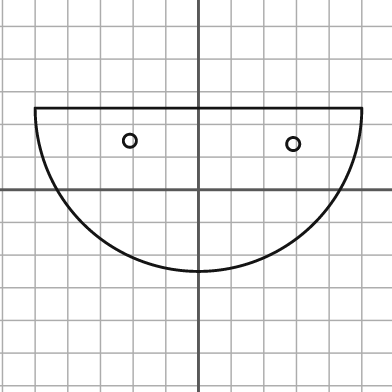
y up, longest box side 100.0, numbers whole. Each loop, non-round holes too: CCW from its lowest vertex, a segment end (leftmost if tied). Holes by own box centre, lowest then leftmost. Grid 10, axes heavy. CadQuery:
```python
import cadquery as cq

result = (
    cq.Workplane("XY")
    .moveTo(-50.0, 25.0)
    .threePointArc((0.0, -25.0), (50.0, 25.0))
    .close()
    .moveTo(29.0, 14.0)
    .circle(2.0)
    .moveTo(-21.0, 15.0)
    .circle(2.0)
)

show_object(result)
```